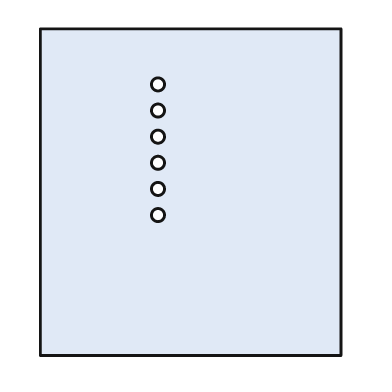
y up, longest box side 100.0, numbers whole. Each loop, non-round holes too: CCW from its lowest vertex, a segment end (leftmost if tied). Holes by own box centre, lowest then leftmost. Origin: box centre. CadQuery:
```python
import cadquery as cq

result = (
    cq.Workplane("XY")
    .moveTo(-46.0, -50.0)
    .lineTo(46.0, -50.0)
    .lineTo(46.0, 50.0)
    .lineTo(-46.0, 50.0)
    .close()
    .moveTo(-10.0, -7.0)
    .circle(2.0)
    .moveTo(-10.0, 1.0)
    .circle(2.0)
    .moveTo(-10.0, 9.0)
    .circle(2.0)
    .moveTo(-10.0, 17.0)
    .circle(2.0)
    .moveTo(-10.0, 25.0)
    .circle(2.0)
    .moveTo(-10.0, 33.0)
    .circle(2.0)
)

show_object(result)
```